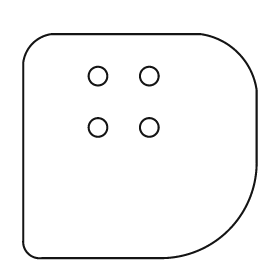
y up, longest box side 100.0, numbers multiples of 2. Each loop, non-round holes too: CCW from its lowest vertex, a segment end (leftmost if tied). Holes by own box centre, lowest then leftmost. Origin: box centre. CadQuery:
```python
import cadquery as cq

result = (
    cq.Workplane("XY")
    .moveTo(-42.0, -48.0)
    .lineTo(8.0, -48.0)
    .threePointArc((38.0, -36.0), (50.0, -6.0))
    .lineTo(50.0, 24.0)
    .threePointArc((42.0, 40.0), (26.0, 48.0))
    .lineTo(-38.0, 48.0)
    .threePointArc((-46.0, 44.0), (-50.0, 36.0))
    .lineTo(-50.0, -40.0)
    .threePointArc((-48.0, -46.0), (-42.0, -48.0))
    .close()
    .moveTo(-18.0, 8.0)
    .circle(4.0)
    .moveTo(4.0, 8.0)
    .circle(4.0)
    .moveTo(-18.0, 30.0)
    .circle(4.0)
    .moveTo(4.0, 30.0)
    .circle(4.0)
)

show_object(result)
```